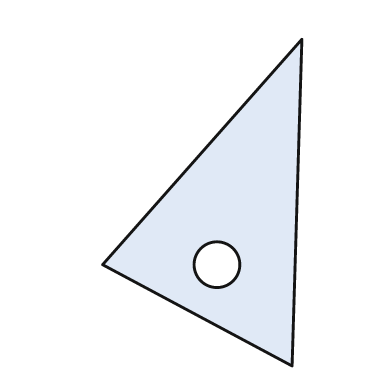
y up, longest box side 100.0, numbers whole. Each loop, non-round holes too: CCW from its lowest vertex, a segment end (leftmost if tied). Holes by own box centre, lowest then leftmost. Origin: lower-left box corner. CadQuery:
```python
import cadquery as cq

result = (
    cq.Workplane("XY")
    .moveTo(58.0, 0.0)
    .lineTo(61.0, 100.0)
    .lineTo(0.0, 31.0)
    .close()
    .moveTo(35.0, 31.0)
    .circle(7.0)
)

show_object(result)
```